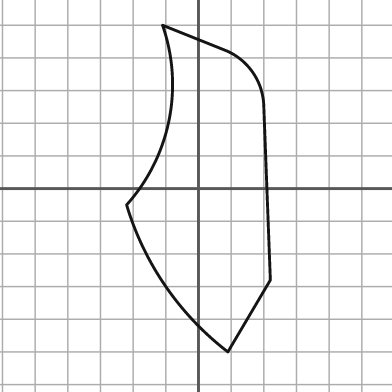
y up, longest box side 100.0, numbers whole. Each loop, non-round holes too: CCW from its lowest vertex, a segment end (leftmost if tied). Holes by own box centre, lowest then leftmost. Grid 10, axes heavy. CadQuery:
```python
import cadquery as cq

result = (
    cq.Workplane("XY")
    .moveTo(9.0, -50.0)
    .lineTo(22.0, -28.0)
    .lineTo(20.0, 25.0)
    .threePointArc((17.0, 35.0), (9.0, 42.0))
    .lineTo(-11.0, 50.0)
    .threePointArc((-9.0, 21.0), (-22.0, -5.0))
    .threePointArc((-10.0, -30.0), (9.0, -50.0))
    .close()
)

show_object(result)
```